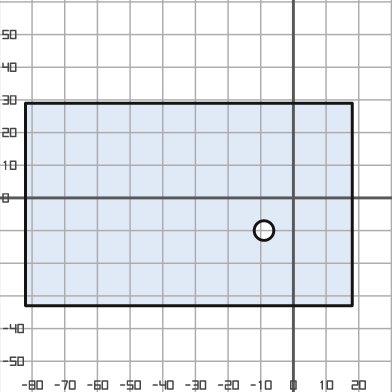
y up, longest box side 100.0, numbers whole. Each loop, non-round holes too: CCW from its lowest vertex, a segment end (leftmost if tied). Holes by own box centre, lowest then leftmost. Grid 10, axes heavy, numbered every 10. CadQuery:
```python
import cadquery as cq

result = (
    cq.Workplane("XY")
    .moveTo(-82.0, -33.0)
    .lineTo(18.0, -33.0)
    .lineTo(18.0, 29.0)
    .lineTo(-82.0, 29.0)
    .close()
    .moveTo(-9.0, -10.0)
    .circle(3.0)
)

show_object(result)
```